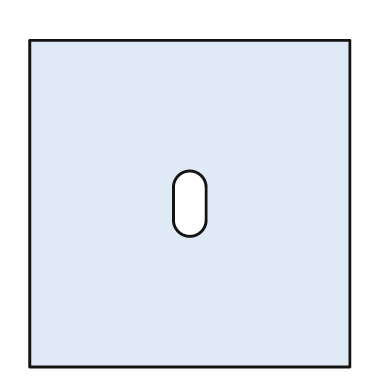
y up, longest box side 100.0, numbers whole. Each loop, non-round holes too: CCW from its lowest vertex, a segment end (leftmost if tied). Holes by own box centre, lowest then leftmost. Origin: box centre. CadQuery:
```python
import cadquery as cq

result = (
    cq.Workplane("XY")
    .moveTo(-49.0, -50.0)
    .lineTo(49.0, -50.0)
    .lineTo(49.0, 50.0)
    .lineTo(-49.0, 50.0)
    .close()
    .moveTo(-5.0, -5.0)
    .threePointArc((0.0, -10.0), (5.0, -5.0))
    .lineTo(5.0, 5.0)
    .threePointArc((0.0, 10.0), (-5.0, 5.0))
    .close()
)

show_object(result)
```